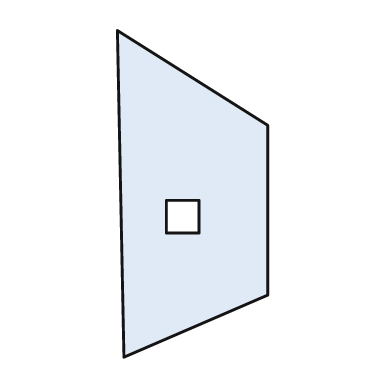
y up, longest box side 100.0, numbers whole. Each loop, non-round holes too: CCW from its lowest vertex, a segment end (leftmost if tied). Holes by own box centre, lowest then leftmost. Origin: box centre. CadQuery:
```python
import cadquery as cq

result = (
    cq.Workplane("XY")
    .moveTo(-21.0, -50.0)
    .lineTo(23.0, -31.0)
    .lineTo(23.0, 21.0)
    .lineTo(-23.0, 50.0)
    .close()
    .moveTo(-8.0, -12.0)
    .lineTo(2.0, -12.0)
    .lineTo(2.0, -2.0)
    .lineTo(-8.0, -2.0)
    .close()
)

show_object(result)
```